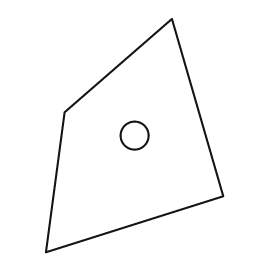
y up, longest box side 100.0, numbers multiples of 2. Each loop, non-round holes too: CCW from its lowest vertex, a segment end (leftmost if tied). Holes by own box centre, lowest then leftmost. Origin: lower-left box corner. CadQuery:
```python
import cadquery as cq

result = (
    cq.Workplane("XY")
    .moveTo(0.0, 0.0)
    .lineTo(76.0, 24.0)
    .lineTo(54.0, 100.0)
    .lineTo(8.0, 60.0)
    .close()
    .moveTo(38.0, 50.0)
    .circle(6.0)
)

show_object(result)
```